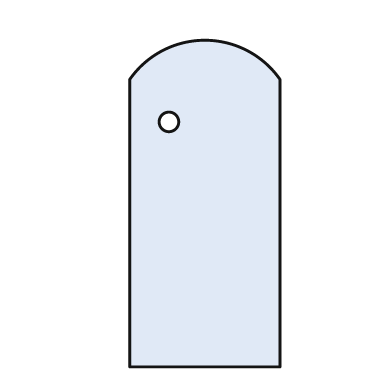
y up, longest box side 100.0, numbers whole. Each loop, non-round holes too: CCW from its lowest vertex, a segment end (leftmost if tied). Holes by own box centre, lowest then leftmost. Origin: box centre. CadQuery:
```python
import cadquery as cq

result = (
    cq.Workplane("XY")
    .moveTo(-23.0, -50.0)
    .lineTo(23.0, -50.0)
    .lineTo(23.0, 38.0)
    .threePointArc((0.0, 50.0), (-23.0, 38.0))
    .close()
    .moveTo(-11.0, 25.0)
    .circle(3.0)
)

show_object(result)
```